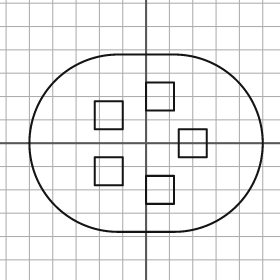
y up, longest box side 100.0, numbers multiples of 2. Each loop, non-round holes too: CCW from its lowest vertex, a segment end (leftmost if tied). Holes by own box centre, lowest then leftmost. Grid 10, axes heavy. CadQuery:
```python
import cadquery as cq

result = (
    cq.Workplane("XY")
    .moveTo(-12.0, -38.0)
    .lineTo(12.0, -38.0)
    .threePointArc((50.0, 0.0), (12.0, 38.0))
    .lineTo(-12.0, 38.0)
    .threePointArc((-50.0, 0.0), (-12.0, -38.0))
    .close()
    .moveTo(0.0, -26.0)
    .lineTo(12.0, -26.0)
    .lineTo(12.0, -14.0)
    .lineTo(0.0, -14.0)
    .close()
    .moveTo(-22.0, -18.0)
    .lineTo(-10.0, -18.0)
    .lineTo(-10.0, -6.0)
    .lineTo(-22.0, -6.0)
    .close()
    .moveTo(14.0, -6.0)
    .lineTo(26.0, -6.0)
    .lineTo(26.0, 6.0)
    .lineTo(14.0, 6.0)
    .close()
    .moveTo(-22.0, 6.0)
    .lineTo(-10.0, 6.0)
    .lineTo(-10.0, 18.0)
    .lineTo(-22.0, 18.0)
    .close()
    .moveTo(0.0, 14.0)
    .lineTo(12.0, 14.0)
    .lineTo(12.0, 26.0)
    .lineTo(0.0, 26.0)
    .close()
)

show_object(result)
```